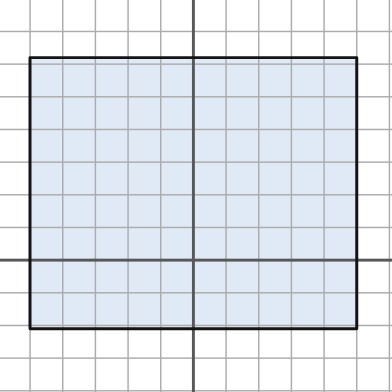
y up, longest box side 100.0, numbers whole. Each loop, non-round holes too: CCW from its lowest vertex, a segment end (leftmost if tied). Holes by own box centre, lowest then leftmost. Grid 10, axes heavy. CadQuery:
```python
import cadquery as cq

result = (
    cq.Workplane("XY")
    .moveTo(-50.0, -21.0)
    .lineTo(50.0, -21.0)
    .lineTo(50.0, 62.0)
    .lineTo(-50.0, 62.0)
    .close()
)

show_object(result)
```